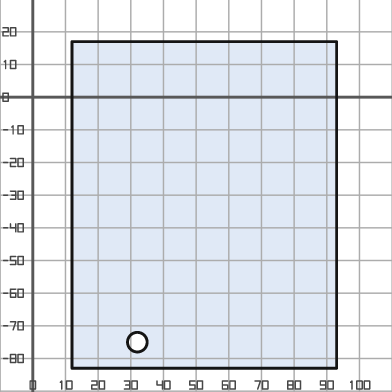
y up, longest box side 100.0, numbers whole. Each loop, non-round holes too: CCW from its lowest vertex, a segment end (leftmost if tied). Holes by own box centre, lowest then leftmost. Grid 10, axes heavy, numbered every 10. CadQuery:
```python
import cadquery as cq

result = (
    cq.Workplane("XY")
    .moveTo(12.0, -83.0)
    .lineTo(93.0, -83.0)
    .lineTo(93.0, 17.0)
    .lineTo(12.0, 17.0)
    .close()
    .moveTo(32.0, -75.0)
    .circle(3.0)
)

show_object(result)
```